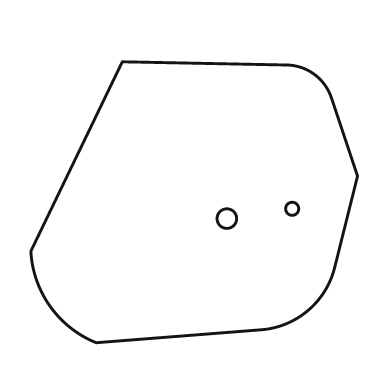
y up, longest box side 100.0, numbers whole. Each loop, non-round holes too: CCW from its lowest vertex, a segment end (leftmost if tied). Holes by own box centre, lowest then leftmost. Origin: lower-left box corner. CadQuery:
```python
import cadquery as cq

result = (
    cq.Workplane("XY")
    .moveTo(20.0, 0.0)
    .lineTo(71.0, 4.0)
    .threePointArc((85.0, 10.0), (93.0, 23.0))
    .lineTo(100.0, 51.0)
    .lineTo(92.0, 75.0)
    .threePointArc((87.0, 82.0), (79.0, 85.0))
    .lineTo(28.0, 86.0)
    .lineTo(0.0, 28.0)
    .threePointArc((6.0, 11.0), (20.0, 0.0))
    .close()
    .moveTo(60.0, 38.0)
    .circle(3.0)
    .moveTo(80.0, 41.0)
    .circle(2.0)
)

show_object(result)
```